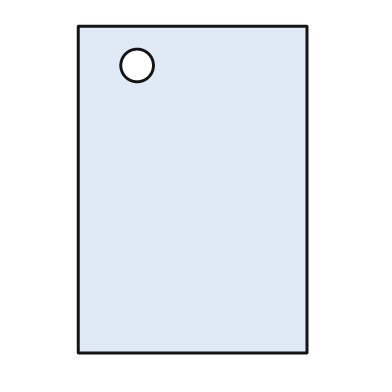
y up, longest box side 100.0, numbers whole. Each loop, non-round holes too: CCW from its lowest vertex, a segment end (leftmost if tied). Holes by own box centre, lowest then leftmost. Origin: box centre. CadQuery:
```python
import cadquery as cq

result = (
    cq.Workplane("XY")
    .moveTo(-35.0, -50.0)
    .lineTo(35.0, -50.0)
    .lineTo(35.0, 50.0)
    .lineTo(-35.0, 50.0)
    .close()
    .moveTo(-17.0, 38.0)
    .circle(5.0)
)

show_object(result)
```